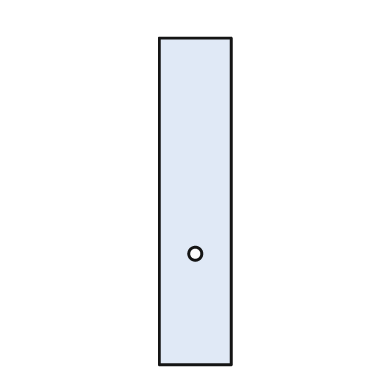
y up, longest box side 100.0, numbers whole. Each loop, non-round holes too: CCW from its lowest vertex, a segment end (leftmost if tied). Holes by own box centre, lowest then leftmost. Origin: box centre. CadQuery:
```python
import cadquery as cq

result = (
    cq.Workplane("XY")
    .moveTo(-11.0, -50.0)
    .lineTo(11.0, -50.0)
    .lineTo(11.0, 50.0)
    .lineTo(-11.0, 50.0)
    .close()
    .moveTo(0.0, -16.0)
    .circle(2.0)
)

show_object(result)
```